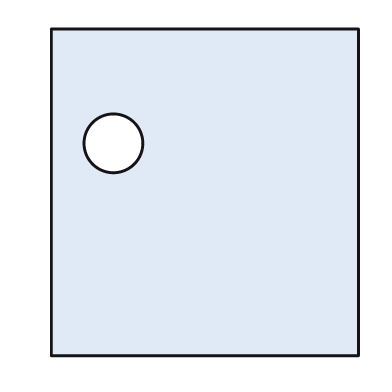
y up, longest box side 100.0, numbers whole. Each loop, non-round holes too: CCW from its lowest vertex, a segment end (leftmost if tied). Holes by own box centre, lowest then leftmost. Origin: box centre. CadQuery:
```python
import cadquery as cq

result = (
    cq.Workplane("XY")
    .moveTo(-47.0, -50.0)
    .lineTo(47.0, -50.0)
    .lineTo(47.0, 50.0)
    .lineTo(-47.0, 50.0)
    .close()
    .moveTo(-28.0, 15.0)
    .circle(9.0)
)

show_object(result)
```